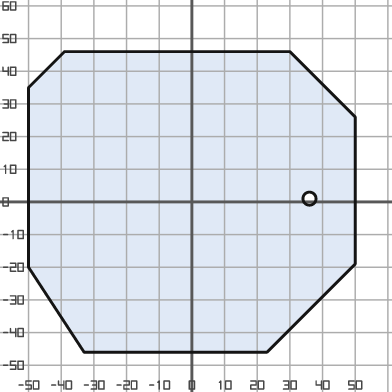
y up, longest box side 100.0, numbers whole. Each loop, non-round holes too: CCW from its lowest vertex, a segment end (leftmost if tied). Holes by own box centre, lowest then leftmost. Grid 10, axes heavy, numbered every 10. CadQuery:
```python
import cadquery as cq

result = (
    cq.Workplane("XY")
    .moveTo(-33.0, -46.0)
    .lineTo(23.0, -46.0)
    .lineTo(50.0, -19.0)
    .lineTo(50.0, 26.0)
    .lineTo(30.0, 46.0)
    .lineTo(-39.0, 46.0)
    .lineTo(-50.0, 35.0)
    .lineTo(-50.0, -20.0)
    .close()
    .moveTo(36.0, 1.0)
    .circle(2.0)
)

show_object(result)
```